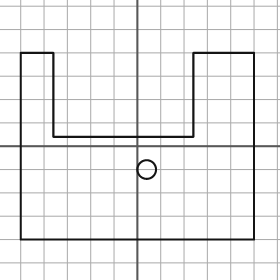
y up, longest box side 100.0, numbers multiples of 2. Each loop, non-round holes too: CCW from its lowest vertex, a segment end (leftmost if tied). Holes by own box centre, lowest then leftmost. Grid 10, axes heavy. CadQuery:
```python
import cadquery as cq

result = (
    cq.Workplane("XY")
    .moveTo(-50.0, -40.0)
    .lineTo(50.0, -40.0)
    .lineTo(50.0, 40.0)
    .lineTo(24.0, 40.0)
    .lineTo(24.0, 4.0)
    .lineTo(-36.0, 4.0)
    .lineTo(-36.0, 40.0)
    .lineTo(-50.0, 40.0)
    .close()
    .moveTo(4.0, -10.0)
    .circle(4.0)
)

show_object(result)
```